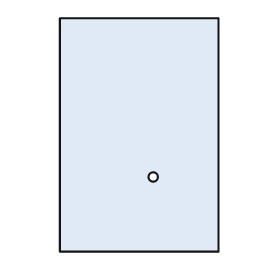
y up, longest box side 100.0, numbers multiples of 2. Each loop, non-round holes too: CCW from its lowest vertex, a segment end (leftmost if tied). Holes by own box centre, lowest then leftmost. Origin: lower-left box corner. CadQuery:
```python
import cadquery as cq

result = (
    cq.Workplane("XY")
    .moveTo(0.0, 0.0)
    .lineTo(68.0, 0.0)
    .lineTo(68.0, 100.0)
    .lineTo(0.0, 100.0)
    .close()
    .moveTo(40.0, 32.0)
    .circle(2.0)
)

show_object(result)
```